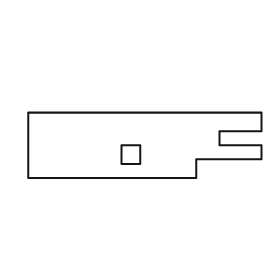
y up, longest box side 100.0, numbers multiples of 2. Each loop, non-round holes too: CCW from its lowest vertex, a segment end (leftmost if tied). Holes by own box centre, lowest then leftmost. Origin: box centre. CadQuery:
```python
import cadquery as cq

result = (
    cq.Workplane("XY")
    .moveTo(-50.0, -14.0)
    .lineTo(22.0, -14.0)
    .lineTo(22.0, -6.0)
    .lineTo(50.0, -6.0)
    .lineTo(50.0, 0.0)
    .lineTo(32.0, 0.0)
    .lineTo(32.0, 6.0)
    .lineTo(50.0, 6.0)
    .lineTo(50.0, 14.0)
    .lineTo(-50.0, 14.0)
    .close()
    .moveTo(-10.0, -8.0)
    .lineTo(-2.0, -8.0)
    .lineTo(-2.0, 0.0)
    .lineTo(-10.0, 0.0)
    .close()
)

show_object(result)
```